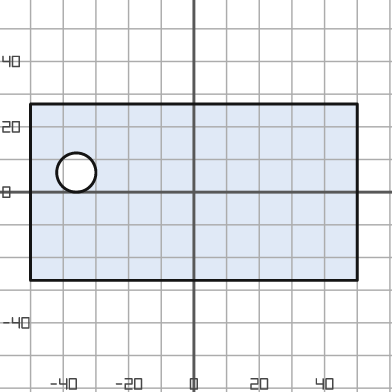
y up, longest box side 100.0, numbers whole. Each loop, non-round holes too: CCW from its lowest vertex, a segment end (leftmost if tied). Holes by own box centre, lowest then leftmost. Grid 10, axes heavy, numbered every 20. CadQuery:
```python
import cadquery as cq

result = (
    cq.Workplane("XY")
    .moveTo(-50.0, -27.0)
    .lineTo(50.0, -27.0)
    .lineTo(50.0, 27.0)
    .lineTo(-50.0, 27.0)
    .close()
    .moveTo(-36.0, 6.0)
    .circle(6.0)
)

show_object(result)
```